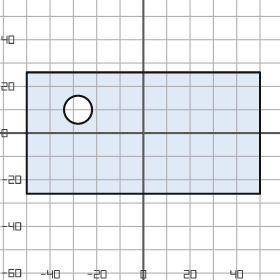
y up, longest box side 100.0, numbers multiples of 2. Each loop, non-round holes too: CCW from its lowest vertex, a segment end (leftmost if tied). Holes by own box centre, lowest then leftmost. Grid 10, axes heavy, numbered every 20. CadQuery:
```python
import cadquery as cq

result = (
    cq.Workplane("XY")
    .moveTo(-50.0, -26.0)
    .lineTo(50.0, -26.0)
    .lineTo(50.0, 26.0)
    .lineTo(-50.0, 26.0)
    .close()
    .moveTo(-28.0, 10.0)
    .circle(6.0)
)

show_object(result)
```